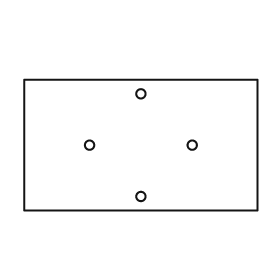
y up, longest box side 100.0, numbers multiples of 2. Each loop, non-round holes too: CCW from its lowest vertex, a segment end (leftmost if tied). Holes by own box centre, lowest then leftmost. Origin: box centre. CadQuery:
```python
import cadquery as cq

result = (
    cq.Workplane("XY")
    .moveTo(-50.0, -28.0)
    .lineTo(50.0, -28.0)
    .lineTo(50.0, 28.0)
    .lineTo(-50.0, 28.0)
    .close()
    .moveTo(0.0, -22.0)
    .circle(2.0)
    .moveTo(-22.0, 0.0)
    .circle(2.0)
    .moveTo(22.0, 0.0)
    .circle(2.0)
    .moveTo(0.0, 22.0)
    .circle(2.0)
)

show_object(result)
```